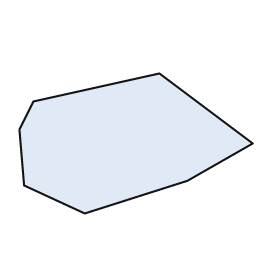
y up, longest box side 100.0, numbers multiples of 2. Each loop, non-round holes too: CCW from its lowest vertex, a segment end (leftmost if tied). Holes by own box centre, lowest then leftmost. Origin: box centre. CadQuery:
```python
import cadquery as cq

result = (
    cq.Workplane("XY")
    .moveTo(-22.0, -30.0)
    .lineTo(22.0, -16.0)
    .lineTo(50.0, 0.0)
    .lineTo(10.0, 30.0)
    .lineTo(-44.0, 18.0)
    .lineTo(-50.0, 6.0)
    .lineTo(-48.0, -18.0)
    .close()
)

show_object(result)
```